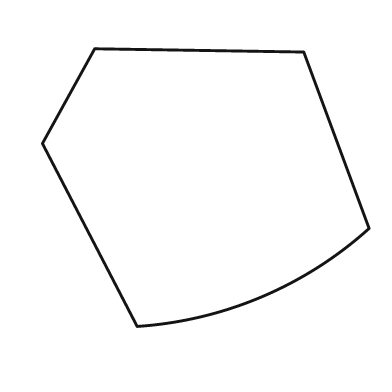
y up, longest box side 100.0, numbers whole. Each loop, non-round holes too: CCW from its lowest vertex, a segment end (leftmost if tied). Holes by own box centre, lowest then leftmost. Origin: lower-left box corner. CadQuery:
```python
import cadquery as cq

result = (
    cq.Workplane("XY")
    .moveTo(29.0, 0.0)
    .threePointArc((67.0, 9.0), (100.0, 30.0))
    .lineTo(80.0, 84.0)
    .lineTo(16.0, 85.0)
    .lineTo(0.0, 56.0)
    .close()
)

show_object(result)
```